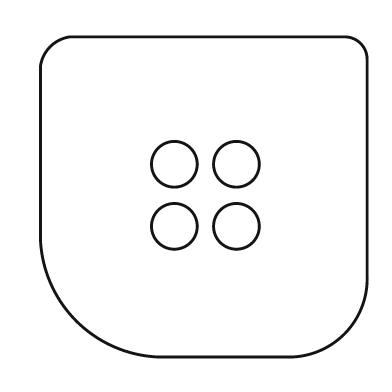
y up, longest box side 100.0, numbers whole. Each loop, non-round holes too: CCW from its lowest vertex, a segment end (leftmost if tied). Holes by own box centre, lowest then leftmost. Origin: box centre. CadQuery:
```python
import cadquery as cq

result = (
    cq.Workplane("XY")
    .moveTo(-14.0, -49.0)
    .lineTo(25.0, -49.0)
    .threePointArc((43.0, -42.0), (50.0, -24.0))
    .lineTo(50.0, 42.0)
    .threePointArc((48.0, 47.0), (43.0, 49.0))
    .lineTo(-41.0, 49.0)
    .threePointArc((-47.0, 46.0), (-50.0, 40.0))
    .lineTo(-50.0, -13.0)
    .threePointArc((-39.0, -38.0), (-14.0, -49.0))
    .close()
    .moveTo(-9.0, -9.0)
    .circle(7.0)
    .moveTo(10.0, -9.0)
    .circle(7.0)
    .moveTo(-9.0, 10.0)
    .circle(7.0)
    .moveTo(10.0, 10.0)
    .circle(7.0)
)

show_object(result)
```